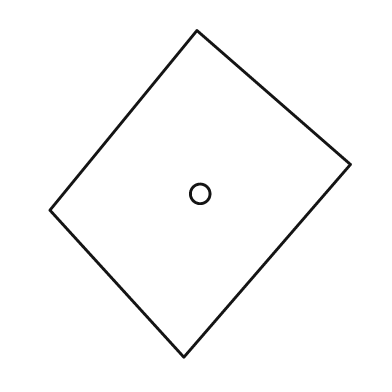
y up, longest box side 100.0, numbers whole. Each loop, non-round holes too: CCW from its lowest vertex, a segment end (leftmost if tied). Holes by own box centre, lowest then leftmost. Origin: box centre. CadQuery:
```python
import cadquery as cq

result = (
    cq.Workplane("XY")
    .moveTo(-5.0, -50.0)
    .lineTo(46.0, 9.0)
    .lineTo(-1.0, 50.0)
    .lineTo(-46.0, -5.0)
    .close()
    .moveTo(0.0, 0.0)
    .circle(3.0)
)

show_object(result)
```